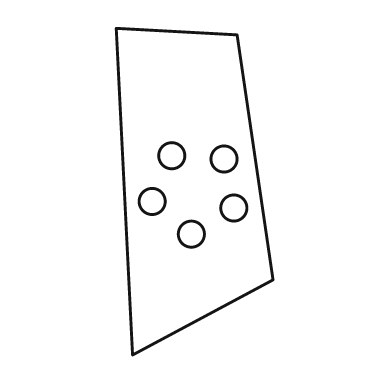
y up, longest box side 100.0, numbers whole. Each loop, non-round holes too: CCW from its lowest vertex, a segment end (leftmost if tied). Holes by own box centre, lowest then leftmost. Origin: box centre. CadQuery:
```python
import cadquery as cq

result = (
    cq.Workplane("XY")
    .moveTo(-19.0, -50.0)
    .lineTo(24.0, -27.0)
    .lineTo(13.0, 48.0)
    .lineTo(-24.0, 50.0)
    .close()
    .moveTo(-1.0, -13.0)
    .circle(4.0)
    .moveTo(12.0, -5.0)
    .circle(4.0)
    .moveTo(-13.0, -3.0)
    .circle(4.0)
    .moveTo(9.0, 10.0)
    .circle(4.0)
    .moveTo(-7.0, 11.0)
    .circle(4.0)
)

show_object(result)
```